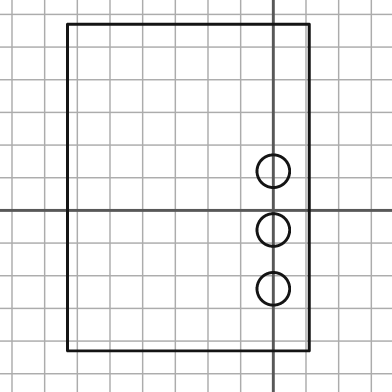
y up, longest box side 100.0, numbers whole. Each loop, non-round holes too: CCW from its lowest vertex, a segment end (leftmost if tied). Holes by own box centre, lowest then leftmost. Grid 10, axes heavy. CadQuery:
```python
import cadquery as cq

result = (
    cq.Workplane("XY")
    .moveTo(-63.0, -43.0)
    .lineTo(11.0, -43.0)
    .lineTo(11.0, 57.0)
    .lineTo(-63.0, 57.0)
    .close()
    .moveTo(0.0, -24.0)
    .circle(5.0)
    .moveTo(0.0, -6.0)
    .circle(5.0)
    .moveTo(0.0, 12.0)
    .circle(5.0)
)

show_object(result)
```